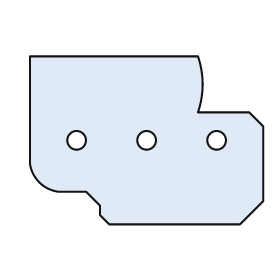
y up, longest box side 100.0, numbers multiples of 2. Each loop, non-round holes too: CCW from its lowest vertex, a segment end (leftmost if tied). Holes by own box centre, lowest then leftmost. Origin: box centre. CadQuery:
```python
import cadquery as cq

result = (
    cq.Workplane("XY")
    .moveTo(-16.0, -36.0)
    .lineTo(40.0, -36.0)
    .lineTo(50.0, -26.0)
    .lineTo(50.0, 6.0)
    .lineTo(44.0, 12.0)
    .lineTo(22.0, 12.0)
    .threePointArc((24.0, 24.0), (22.0, 36.0))
    .lineTo(-50.0, 36.0)
    .lineTo(-50.0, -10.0)
    .threePointArc((-46.0, -18.0), (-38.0, -22.0))
    .lineTo(-26.0, -22.0)
    .lineTo(-20.0, -28.0)
    .lineTo(-20.0, -32.0)
    .close()
    .moveTo(-30.0, 0.0)
    .circle(4.0)
    .moveTo(0.0, 0.0)
    .circle(4.0)
    .moveTo(30.0, 0.0)
    .circle(4.0)
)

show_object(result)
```